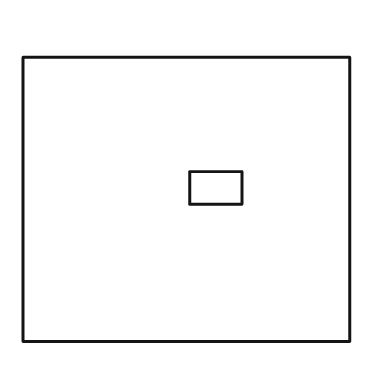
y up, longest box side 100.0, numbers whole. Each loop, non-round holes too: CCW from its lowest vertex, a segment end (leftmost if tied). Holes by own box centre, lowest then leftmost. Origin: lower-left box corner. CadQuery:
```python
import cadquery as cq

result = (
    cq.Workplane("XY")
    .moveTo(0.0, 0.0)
    .lineTo(100.0, 0.0)
    .lineTo(100.0, 87.0)
    .lineTo(0.0, 87.0)
    .close()
    .moveTo(51.0, 42.0)
    .lineTo(67.0, 42.0)
    .lineTo(67.0, 52.0)
    .lineTo(51.0, 52.0)
    .close()
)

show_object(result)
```